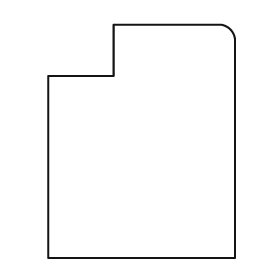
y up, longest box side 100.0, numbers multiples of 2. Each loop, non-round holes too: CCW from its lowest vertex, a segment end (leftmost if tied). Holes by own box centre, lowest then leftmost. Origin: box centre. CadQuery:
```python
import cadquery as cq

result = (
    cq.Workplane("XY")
    .moveTo(-40.0, -50.0)
    .lineTo(40.0, -50.0)
    .lineTo(40.0, 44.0)
    .threePointArc((38.0, 48.0), (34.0, 50.0))
    .lineTo(-12.0, 50.0)
    .lineTo(-12.0, 28.0)
    .lineTo(-40.0, 28.0)
    .close()
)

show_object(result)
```